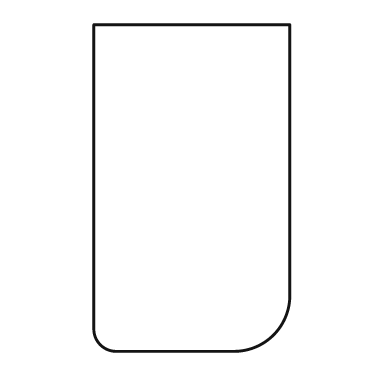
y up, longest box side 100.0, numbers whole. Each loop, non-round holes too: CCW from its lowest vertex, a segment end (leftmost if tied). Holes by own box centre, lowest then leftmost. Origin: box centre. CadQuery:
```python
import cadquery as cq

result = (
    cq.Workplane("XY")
    .moveTo(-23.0, -50.0)
    .lineTo(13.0, -50.0)
    .threePointArc((25.0, -45.0), (30.0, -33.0))
    .lineTo(30.0, 50.0)
    .lineTo(-30.0, 50.0)
    .lineTo(-30.0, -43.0)
    .threePointArc((-28.0, -48.0), (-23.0, -50.0))
    .close()
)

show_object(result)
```